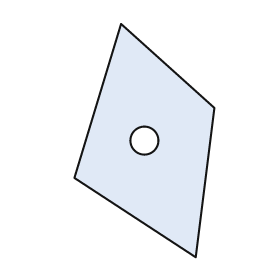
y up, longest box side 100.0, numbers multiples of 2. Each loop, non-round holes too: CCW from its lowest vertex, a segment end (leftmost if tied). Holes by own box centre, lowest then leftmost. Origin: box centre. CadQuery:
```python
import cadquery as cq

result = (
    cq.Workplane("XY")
    .moveTo(22.0, -50.0)
    .lineTo(30.0, 14.0)
    .lineTo(-10.0, 50.0)
    .lineTo(-30.0, -16.0)
    .close()
    .moveTo(0.0, 0.0)
    .circle(6.0)
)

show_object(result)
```